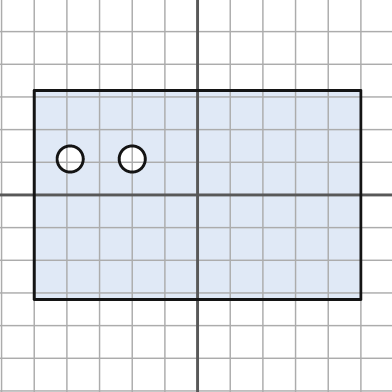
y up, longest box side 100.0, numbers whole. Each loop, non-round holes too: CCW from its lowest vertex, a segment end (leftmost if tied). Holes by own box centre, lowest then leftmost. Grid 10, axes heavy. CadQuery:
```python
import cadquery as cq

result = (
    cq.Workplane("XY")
    .moveTo(-50.0, -32.0)
    .lineTo(50.0, -32.0)
    .lineTo(50.0, 32.0)
    .lineTo(-50.0, 32.0)
    .close()
    .moveTo(-39.0, 11.0)
    .circle(4.0)
    .moveTo(-20.0, 11.0)
    .circle(4.0)
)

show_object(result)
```